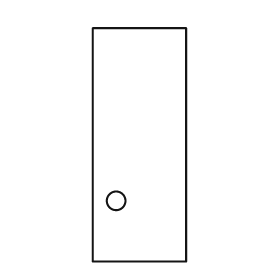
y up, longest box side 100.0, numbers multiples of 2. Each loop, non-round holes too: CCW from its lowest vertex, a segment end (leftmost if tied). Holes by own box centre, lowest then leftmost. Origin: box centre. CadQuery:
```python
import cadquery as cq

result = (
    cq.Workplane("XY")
    .moveTo(-20.0, -50.0)
    .lineTo(20.0, -50.0)
    .lineTo(20.0, 50.0)
    .lineTo(-20.0, 50.0)
    .close()
    .moveTo(-10.0, -24.0)
    .circle(4.0)
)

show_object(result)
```